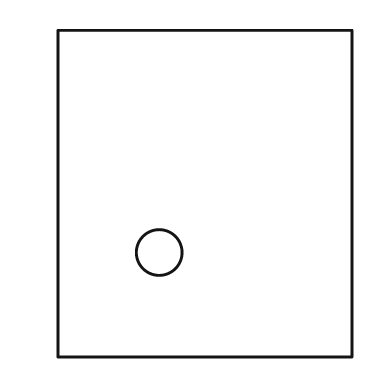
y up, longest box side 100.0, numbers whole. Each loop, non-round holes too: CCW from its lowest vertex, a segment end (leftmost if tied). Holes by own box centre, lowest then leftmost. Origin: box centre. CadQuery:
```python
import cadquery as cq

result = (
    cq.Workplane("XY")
    .moveTo(-45.0, -50.0)
    .lineTo(45.0, -50.0)
    .lineTo(45.0, 50.0)
    .lineTo(-45.0, 50.0)
    .close()
    .moveTo(-14.0, -18.0)
    .circle(7.0)
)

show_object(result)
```